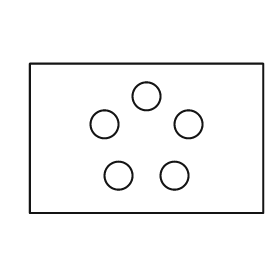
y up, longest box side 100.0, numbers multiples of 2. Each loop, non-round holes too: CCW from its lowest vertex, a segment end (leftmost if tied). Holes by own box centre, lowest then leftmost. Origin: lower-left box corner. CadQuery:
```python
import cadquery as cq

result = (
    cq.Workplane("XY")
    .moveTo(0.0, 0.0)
    .lineTo(100.0, 0.0)
    .lineTo(100.0, 64.0)
    .lineTo(0.0, 64.0)
    .close()
    .moveTo(38.0, 16.0)
    .circle(6.0)
    .moveTo(62.0, 16.0)
    .circle(6.0)
    .moveTo(32.0, 38.0)
    .circle(6.0)
    .moveTo(68.0, 38.0)
    .circle(6.0)
    .moveTo(50.0, 50.0)
    .circle(6.0)
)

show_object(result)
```